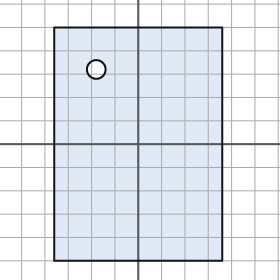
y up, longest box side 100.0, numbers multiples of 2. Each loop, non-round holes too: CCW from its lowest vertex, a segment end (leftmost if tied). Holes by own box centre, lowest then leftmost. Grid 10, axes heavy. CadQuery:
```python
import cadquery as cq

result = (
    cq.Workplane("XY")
    .moveTo(-36.0, -50.0)
    .lineTo(36.0, -50.0)
    .lineTo(36.0, 50.0)
    .lineTo(-36.0, 50.0)
    .close()
    .moveTo(-18.0, 32.0)
    .circle(4.0)
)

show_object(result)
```